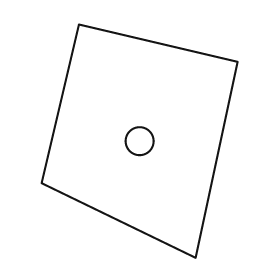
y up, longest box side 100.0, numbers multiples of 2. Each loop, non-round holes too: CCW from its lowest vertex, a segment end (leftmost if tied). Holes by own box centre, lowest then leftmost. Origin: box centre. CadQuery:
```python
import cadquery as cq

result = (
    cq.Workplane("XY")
    .moveTo(24.0, -50.0)
    .lineTo(42.0, 34.0)
    .lineTo(-26.0, 50.0)
    .lineTo(-42.0, -18.0)
    .close()
    .moveTo(0.0, 0.0)
    .circle(6.0)
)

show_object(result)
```